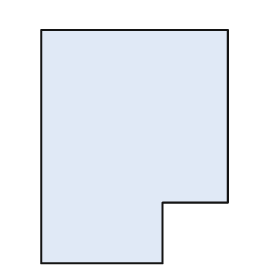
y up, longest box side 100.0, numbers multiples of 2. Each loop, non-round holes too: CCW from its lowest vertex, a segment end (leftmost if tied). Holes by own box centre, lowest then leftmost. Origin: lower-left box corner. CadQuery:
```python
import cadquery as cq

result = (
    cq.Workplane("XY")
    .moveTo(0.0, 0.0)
    .lineTo(52.0, 0.0)
    .lineTo(52.0, 26.0)
    .lineTo(80.0, 26.0)
    .lineTo(80.0, 100.0)
    .lineTo(0.0, 100.0)
    .close()
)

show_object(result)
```